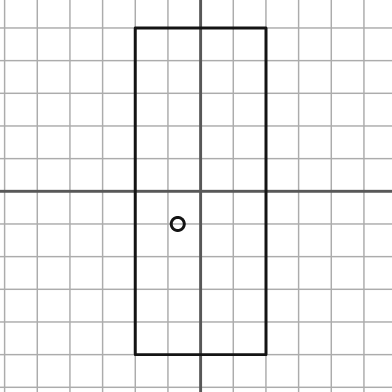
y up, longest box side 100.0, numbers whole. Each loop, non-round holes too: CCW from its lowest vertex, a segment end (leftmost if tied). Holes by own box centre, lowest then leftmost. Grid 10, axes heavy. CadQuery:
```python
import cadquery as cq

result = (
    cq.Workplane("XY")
    .moveTo(-20.0, -50.0)
    .lineTo(20.0, -50.0)
    .lineTo(20.0, 50.0)
    .lineTo(-20.0, 50.0)
    .close()
    .moveTo(-7.0, -10.0)
    .circle(2.0)
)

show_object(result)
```